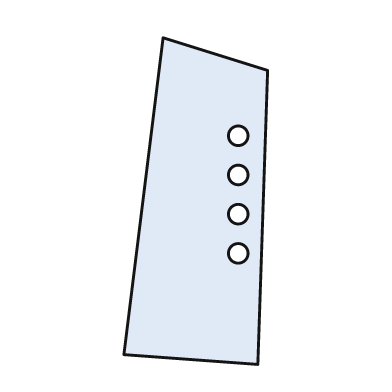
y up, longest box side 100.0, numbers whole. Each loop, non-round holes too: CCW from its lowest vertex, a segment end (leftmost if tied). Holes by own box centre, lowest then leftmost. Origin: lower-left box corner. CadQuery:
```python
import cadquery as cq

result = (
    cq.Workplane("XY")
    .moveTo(41.0, 0.0)
    .lineTo(44.0, 90.0)
    .lineTo(12.0, 100.0)
    .lineTo(0.0, 3.0)
    .close()
    .moveTo(35.0, 34.0)
    .circle(3.0)
    .moveTo(35.0, 46.0)
    .circle(3.0)
    .moveTo(35.0, 58.0)
    .circle(3.0)
    .moveTo(35.0, 70.0)
    .circle(3.0)
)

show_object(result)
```